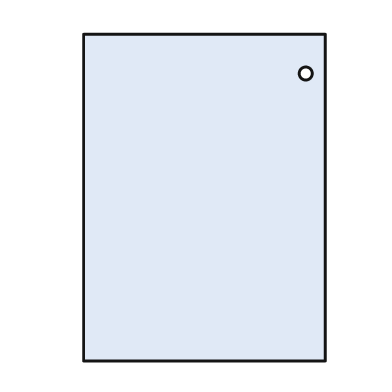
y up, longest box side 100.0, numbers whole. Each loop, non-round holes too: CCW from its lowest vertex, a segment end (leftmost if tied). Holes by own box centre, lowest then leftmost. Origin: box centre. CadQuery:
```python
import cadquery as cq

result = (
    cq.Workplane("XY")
    .moveTo(-37.0, -50.0)
    .lineTo(37.0, -50.0)
    .lineTo(37.0, 50.0)
    .lineTo(-37.0, 50.0)
    .close()
    .moveTo(31.0, 38.0)
    .circle(2.0)
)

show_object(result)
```